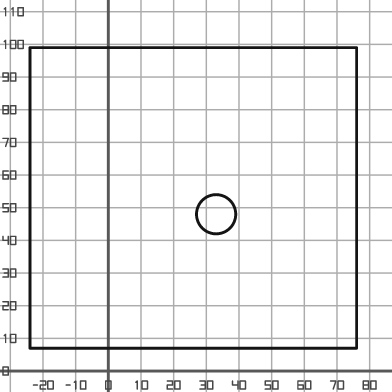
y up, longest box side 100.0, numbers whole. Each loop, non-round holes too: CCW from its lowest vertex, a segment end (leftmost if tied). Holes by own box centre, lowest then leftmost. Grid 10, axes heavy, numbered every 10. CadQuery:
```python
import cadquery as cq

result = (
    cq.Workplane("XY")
    .moveTo(-24.0, 7.0)
    .lineTo(76.0, 7.0)
    .lineTo(76.0, 99.0)
    .lineTo(-24.0, 99.0)
    .close()
    .moveTo(33.0, 48.0)
    .circle(6.0)
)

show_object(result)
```